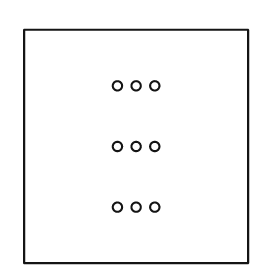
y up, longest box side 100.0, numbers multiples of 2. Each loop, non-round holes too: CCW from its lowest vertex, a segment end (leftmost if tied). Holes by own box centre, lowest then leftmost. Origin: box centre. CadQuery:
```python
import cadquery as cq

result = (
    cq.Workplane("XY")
    .moveTo(-48.0, -50.0)
    .lineTo(48.0, -50.0)
    .lineTo(48.0, 50.0)
    .lineTo(-48.0, 50.0)
    .close()
    .moveTo(-8.0, -26.0)
    .circle(2.0)
    .moveTo(0.0, -26.0)
    .circle(2.0)
    .moveTo(8.0, -26.0)
    .circle(2.0)
    .moveTo(-8.0, 0.0)
    .circle(2.0)
    .moveTo(0.0, 0.0)
    .circle(2.0)
    .moveTo(8.0, 0.0)
    .circle(2.0)
    .moveTo(-8.0, 26.0)
    .circle(2.0)
    .moveTo(0.0, 26.0)
    .circle(2.0)
    .moveTo(8.0, 26.0)
    .circle(2.0)
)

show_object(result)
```